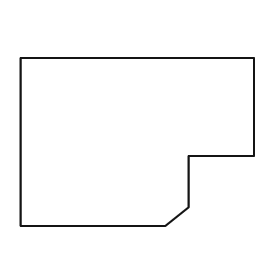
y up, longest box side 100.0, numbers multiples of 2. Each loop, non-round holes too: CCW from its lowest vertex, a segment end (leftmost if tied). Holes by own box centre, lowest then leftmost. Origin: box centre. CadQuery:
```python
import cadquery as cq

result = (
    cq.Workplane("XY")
    .moveTo(-50.0, -36.0)
    .lineTo(12.0, -36.0)
    .lineTo(22.0, -28.0)
    .lineTo(22.0, -6.0)
    .lineTo(50.0, -6.0)
    .lineTo(50.0, 36.0)
    .lineTo(-50.0, 36.0)
    .close()
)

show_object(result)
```